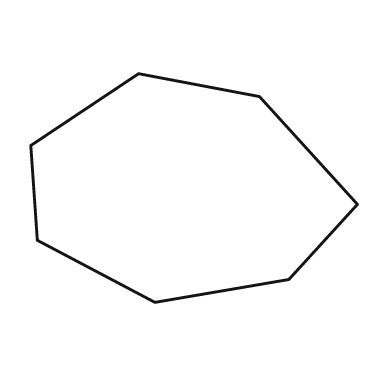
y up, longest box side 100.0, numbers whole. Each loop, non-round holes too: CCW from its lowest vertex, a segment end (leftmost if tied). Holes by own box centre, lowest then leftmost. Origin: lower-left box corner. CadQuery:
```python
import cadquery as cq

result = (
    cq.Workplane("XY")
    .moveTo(38.0, 0.0)
    .lineTo(79.0, 7.0)
    .lineTo(100.0, 30.0)
    .lineTo(70.0, 63.0)
    .lineTo(33.0, 70.0)
    .lineTo(0.0, 48.0)
    .lineTo(2.0, 19.0)
    .close()
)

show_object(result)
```